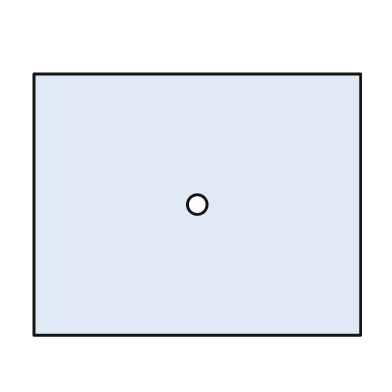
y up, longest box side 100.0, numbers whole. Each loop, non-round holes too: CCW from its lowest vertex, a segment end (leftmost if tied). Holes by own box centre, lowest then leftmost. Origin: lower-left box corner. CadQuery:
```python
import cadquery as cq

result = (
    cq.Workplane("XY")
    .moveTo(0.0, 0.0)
    .lineTo(100.0, 0.0)
    .lineTo(100.0, 80.0)
    .lineTo(0.0, 80.0)
    .close()
    .moveTo(50.0, 40.0)
    .circle(3.0)
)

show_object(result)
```